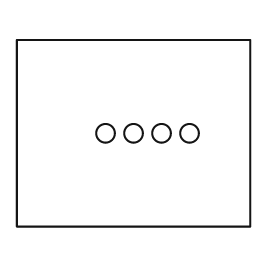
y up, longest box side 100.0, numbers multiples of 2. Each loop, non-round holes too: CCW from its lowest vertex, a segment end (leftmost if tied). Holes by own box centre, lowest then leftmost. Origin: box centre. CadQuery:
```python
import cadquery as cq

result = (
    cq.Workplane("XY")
    .moveTo(-50.0, -40.0)
    .lineTo(50.0, -40.0)
    .lineTo(50.0, 40.0)
    .lineTo(-50.0, 40.0)
    .close()
    .moveTo(-12.0, 0.0)
    .circle(4.0)
    .moveTo(0.0, 0.0)
    .circle(4.0)
    .moveTo(12.0, 0.0)
    .circle(4.0)
    .moveTo(24.0, 0.0)
    .circle(4.0)
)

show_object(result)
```